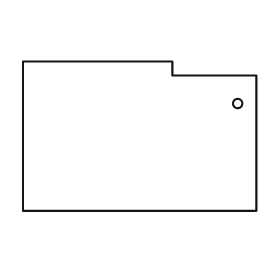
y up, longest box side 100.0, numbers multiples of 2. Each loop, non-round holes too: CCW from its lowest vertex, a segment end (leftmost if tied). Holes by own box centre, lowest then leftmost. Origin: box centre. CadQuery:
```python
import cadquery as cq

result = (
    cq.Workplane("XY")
    .moveTo(-50.0, -32.0)
    .lineTo(50.0, -32.0)
    .lineTo(50.0, 26.0)
    .lineTo(14.0, 26.0)
    .lineTo(14.0, 32.0)
    .lineTo(-50.0, 32.0)
    .close()
    .moveTo(42.0, 14.0)
    .circle(2.0)
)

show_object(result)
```